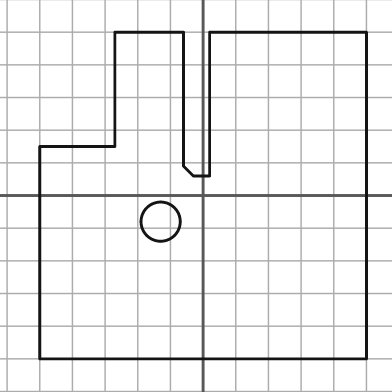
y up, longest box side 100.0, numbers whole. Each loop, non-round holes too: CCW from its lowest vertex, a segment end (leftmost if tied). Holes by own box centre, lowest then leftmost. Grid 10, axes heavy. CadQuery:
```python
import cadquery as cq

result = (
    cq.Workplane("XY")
    .moveTo(-50.0, -50.0)
    .lineTo(50.0, -50.0)
    .lineTo(50.0, 50.0)
    .lineTo(2.0, 50.0)
    .lineTo(2.0, 6.0)
    .lineTo(-3.0, 6.0)
    .lineTo(-6.0, 9.0)
    .lineTo(-6.0, 50.0)
    .lineTo(-27.0, 50.0)
    .lineTo(-27.0, 15.0)
    .lineTo(-50.0, 15.0)
    .close()
    .moveTo(-13.0, -8.0)
    .circle(6.0)
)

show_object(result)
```